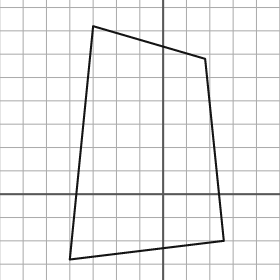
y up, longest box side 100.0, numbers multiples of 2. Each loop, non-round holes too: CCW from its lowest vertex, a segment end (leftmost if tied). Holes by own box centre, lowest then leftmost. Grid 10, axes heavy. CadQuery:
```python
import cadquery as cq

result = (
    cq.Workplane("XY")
    .moveTo(-40.0, -28.0)
    .lineTo(26.0, -20.0)
    .lineTo(18.0, 58.0)
    .lineTo(-30.0, 72.0)
    .close()
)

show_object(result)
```